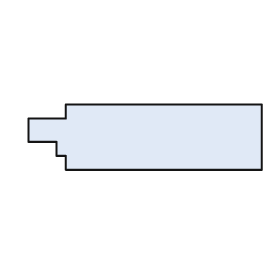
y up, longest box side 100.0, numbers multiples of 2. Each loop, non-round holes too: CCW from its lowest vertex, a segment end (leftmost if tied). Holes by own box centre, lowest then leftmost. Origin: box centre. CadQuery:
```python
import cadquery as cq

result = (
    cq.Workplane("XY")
    .moveTo(-34.0, -14.0)
    .lineTo(50.0, -14.0)
    .lineTo(50.0, 14.0)
    .lineTo(-34.0, 14.0)
    .lineTo(-34.0, 8.0)
    .lineTo(-50.0, 8.0)
    .lineTo(-50.0, -2.0)
    .lineTo(-38.0, -2.0)
    .lineTo(-38.0, -8.0)
    .lineTo(-34.0, -8.0)
    .close()
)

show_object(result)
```